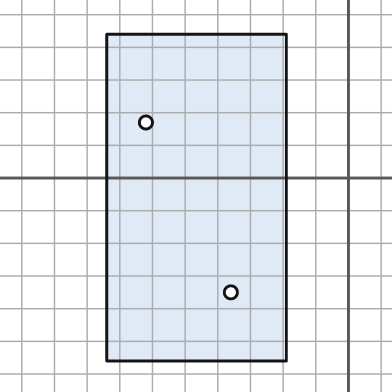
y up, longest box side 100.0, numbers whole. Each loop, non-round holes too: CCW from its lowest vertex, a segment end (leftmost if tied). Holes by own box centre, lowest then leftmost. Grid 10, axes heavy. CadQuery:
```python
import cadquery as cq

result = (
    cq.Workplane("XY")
    .moveTo(-74.0, -56.0)
    .lineTo(-19.0, -56.0)
    .lineTo(-19.0, 44.0)
    .lineTo(-74.0, 44.0)
    .close()
    .moveTo(-36.0, -35.0)
    .circle(2.0)
    .moveTo(-62.0, 17.0)
    .circle(2.0)
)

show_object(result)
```